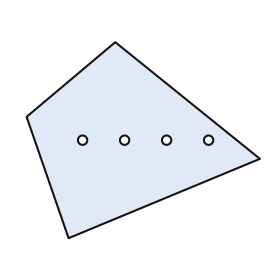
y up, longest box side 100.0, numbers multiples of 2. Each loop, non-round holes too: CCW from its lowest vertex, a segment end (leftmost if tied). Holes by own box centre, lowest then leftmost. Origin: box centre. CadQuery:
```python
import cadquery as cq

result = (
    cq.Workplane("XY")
    .moveTo(-32.0, -42.0)
    .lineTo(50.0, -8.0)
    .lineTo(-12.0, 42.0)
    .lineTo(-50.0, 10.0)
    .close()
    .moveTo(-26.0, 0.0)
    .circle(2.0)
    .moveTo(-8.0, 0.0)
    .circle(2.0)
    .moveTo(10.0, 0.0)
    .circle(2.0)
    .moveTo(28.0, 0.0)
    .circle(2.0)
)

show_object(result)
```